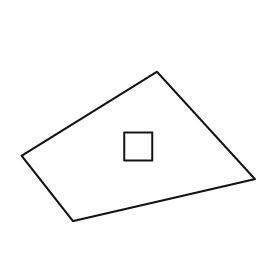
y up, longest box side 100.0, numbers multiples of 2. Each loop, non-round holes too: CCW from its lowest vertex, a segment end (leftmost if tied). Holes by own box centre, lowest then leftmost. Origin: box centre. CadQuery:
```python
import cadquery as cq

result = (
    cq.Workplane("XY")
    .moveTo(-28.0, -32.0)
    .lineTo(50.0, -14.0)
    .lineTo(8.0, 32.0)
    .lineTo(-50.0, -4.0)
    .close()
    .moveTo(-6.0, -6.0)
    .lineTo(6.0, -6.0)
    .lineTo(6.0, 6.0)
    .lineTo(-6.0, 6.0)
    .close()
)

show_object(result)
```